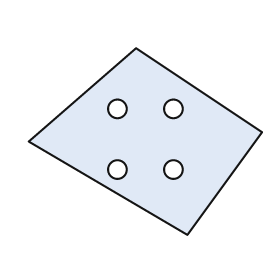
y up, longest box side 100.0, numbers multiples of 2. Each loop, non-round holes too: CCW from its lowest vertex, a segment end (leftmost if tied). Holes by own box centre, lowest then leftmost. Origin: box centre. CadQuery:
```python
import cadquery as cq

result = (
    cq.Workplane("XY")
    .moveTo(18.0, -40.0)
    .lineTo(50.0, 4.0)
    .lineTo(-4.0, 40.0)
    .lineTo(-50.0, 0.0)
    .close()
    .moveTo(-12.0, -12.0)
    .circle(4.0)
    .moveTo(12.0, -12.0)
    .circle(4.0)
    .moveTo(-12.0, 14.0)
    .circle(4.0)
    .moveTo(12.0, 14.0)
    .circle(4.0)
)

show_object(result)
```